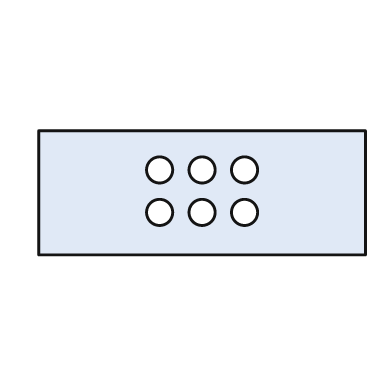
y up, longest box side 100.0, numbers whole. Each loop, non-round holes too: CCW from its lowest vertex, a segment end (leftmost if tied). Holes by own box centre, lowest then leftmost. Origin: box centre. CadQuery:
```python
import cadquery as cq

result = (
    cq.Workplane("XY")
    .moveTo(-50.0, -19.0)
    .lineTo(50.0, -19.0)
    .lineTo(50.0, 19.0)
    .lineTo(-50.0, 19.0)
    .close()
    .moveTo(-13.0, -6.0)
    .circle(4.0)
    .moveTo(0.0, -6.0)
    .circle(4.0)
    .moveTo(13.0, -6.0)
    .circle(4.0)
    .moveTo(-13.0, 7.0)
    .circle(4.0)
    .moveTo(0.0, 7.0)
    .circle(4.0)
    .moveTo(13.0, 7.0)
    .circle(4.0)
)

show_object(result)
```